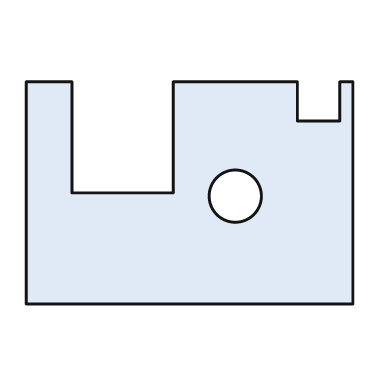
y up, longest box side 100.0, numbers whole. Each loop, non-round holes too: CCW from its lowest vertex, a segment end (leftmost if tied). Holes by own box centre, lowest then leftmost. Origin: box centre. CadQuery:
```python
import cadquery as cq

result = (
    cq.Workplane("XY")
    .moveTo(-50.0, -34.0)
    .lineTo(50.0, -34.0)
    .lineTo(50.0, 34.0)
    .lineTo(46.0, 34.0)
    .lineTo(46.0, 22.0)
    .lineTo(33.0, 22.0)
    .lineTo(33.0, 34.0)
    .lineTo(-5.0, 34.0)
    .lineTo(-5.0, 0.0)
    .lineTo(-36.0, 0.0)
    .lineTo(-36.0, 34.0)
    .lineTo(-50.0, 34.0)
    .close()
    .moveTo(14.0, -1.0)
    .circle(8.0)
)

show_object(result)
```